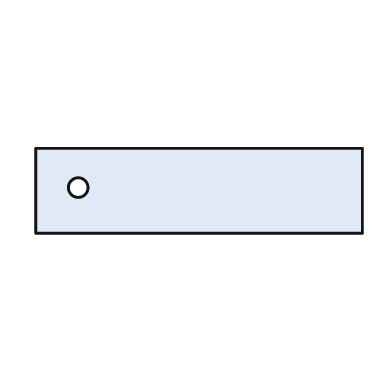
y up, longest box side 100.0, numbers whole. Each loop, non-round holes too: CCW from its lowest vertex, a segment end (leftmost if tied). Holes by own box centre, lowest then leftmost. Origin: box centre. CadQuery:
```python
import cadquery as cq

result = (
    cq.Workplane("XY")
    .moveTo(-50.0, -13.0)
    .lineTo(50.0, -13.0)
    .lineTo(50.0, 13.0)
    .lineTo(-50.0, 13.0)
    .close()
    .moveTo(-37.0, 1.0)
    .circle(3.0)
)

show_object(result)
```